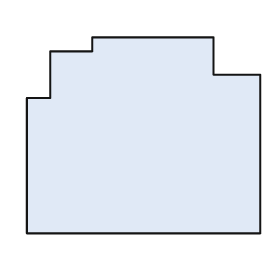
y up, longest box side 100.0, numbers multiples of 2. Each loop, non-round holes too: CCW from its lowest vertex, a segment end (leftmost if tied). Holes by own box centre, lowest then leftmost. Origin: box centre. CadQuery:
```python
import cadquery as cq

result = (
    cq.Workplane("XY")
    .moveTo(-50.0, -42.0)
    .lineTo(50.0, -42.0)
    .lineTo(50.0, 26.0)
    .lineTo(30.0, 26.0)
    .lineTo(30.0, 42.0)
    .lineTo(-22.0, 42.0)
    .lineTo(-22.0, 36.0)
    .lineTo(-40.0, 36.0)
    .lineTo(-40.0, 16.0)
    .lineTo(-50.0, 16.0)
    .close()
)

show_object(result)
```